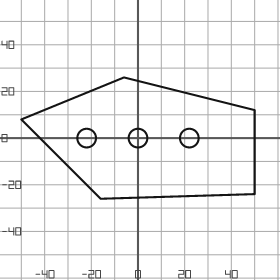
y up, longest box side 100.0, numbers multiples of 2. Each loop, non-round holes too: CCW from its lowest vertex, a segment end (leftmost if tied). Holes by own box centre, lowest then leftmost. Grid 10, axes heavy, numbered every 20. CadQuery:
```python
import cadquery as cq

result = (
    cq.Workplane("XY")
    .moveTo(-16.0, -26.0)
    .lineTo(50.0, -24.0)
    .lineTo(50.0, 12.0)
    .lineTo(-6.0, 26.0)
    .lineTo(-50.0, 8.0)
    .close()
    .moveTo(-22.0, 0.0)
    .circle(4.0)
    .moveTo(0.0, 0.0)
    .circle(4.0)
    .moveTo(22.0, 0.0)
    .circle(4.0)
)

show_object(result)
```